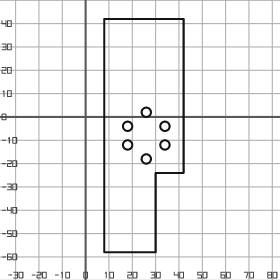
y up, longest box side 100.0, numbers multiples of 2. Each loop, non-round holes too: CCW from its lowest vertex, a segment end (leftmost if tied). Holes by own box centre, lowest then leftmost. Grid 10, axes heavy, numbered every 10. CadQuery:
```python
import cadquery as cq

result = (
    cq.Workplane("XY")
    .moveTo(8.0, -58.0)
    .lineTo(30.0, -58.0)
    .lineTo(30.0, -24.0)
    .lineTo(42.0, -24.0)
    .lineTo(42.0, 42.0)
    .lineTo(8.0, 42.0)
    .close()
    .moveTo(26.0, -18.0)
    .circle(2.0)
    .moveTo(18.0, -12.0)
    .circle(2.0)
    .moveTo(34.0, -12.0)
    .circle(2.0)
    .moveTo(18.0, -4.0)
    .circle(2.0)
    .moveTo(34.0, -4.0)
    .circle(2.0)
    .moveTo(26.0, 2.0)
    .circle(2.0)
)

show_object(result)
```